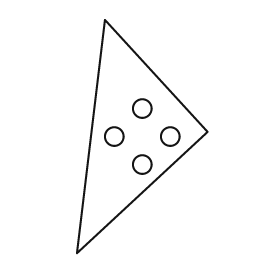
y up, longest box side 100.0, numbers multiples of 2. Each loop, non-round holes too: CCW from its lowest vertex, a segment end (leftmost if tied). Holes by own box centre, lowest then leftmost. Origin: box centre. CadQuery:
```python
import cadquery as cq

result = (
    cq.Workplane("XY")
    .moveTo(-28.0, -50.0)
    .lineTo(28.0, 2.0)
    .lineTo(-16.0, 50.0)
    .close()
    .moveTo(0.0, -12.0)
    .circle(4.0)
    .moveTo(-12.0, 0.0)
    .circle(4.0)
    .moveTo(12.0, 0.0)
    .circle(4.0)
    .moveTo(0.0, 12.0)
    .circle(4.0)
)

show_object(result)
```